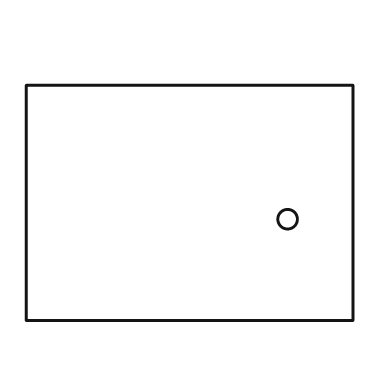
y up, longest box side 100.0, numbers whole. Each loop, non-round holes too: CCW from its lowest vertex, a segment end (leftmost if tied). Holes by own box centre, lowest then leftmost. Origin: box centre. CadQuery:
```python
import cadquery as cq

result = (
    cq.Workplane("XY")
    .moveTo(-50.0, -36.0)
    .lineTo(50.0, -36.0)
    .lineTo(50.0, 36.0)
    .lineTo(-50.0, 36.0)
    .close()
    .moveTo(30.0, -5.0)
    .circle(3.0)
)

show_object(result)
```